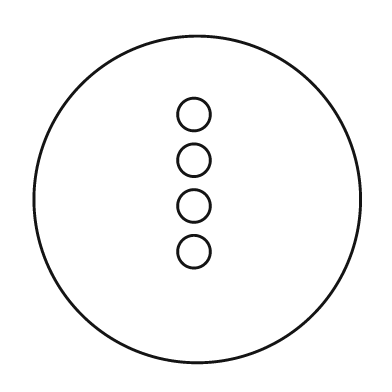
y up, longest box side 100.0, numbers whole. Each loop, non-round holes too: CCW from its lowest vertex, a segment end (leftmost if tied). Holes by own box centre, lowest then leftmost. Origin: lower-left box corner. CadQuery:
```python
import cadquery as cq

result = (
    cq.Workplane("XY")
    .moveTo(50.0, 50.0)
    .circle(50.0)
    .moveTo(49.0, 34.0)
    .circle(5.0)
    .moveTo(49.0, 48.0)
    .circle(5.0)
    .moveTo(49.0, 62.0)
    .circle(5.0)
    .moveTo(49.0, 76.0)
    .circle(5.0)
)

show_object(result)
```